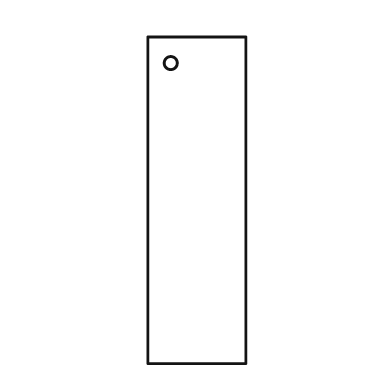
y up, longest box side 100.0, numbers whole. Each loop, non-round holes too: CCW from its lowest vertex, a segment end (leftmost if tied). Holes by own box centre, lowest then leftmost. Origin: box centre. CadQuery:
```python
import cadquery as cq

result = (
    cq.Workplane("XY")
    .moveTo(-15.0, -50.0)
    .lineTo(15.0, -50.0)
    .lineTo(15.0, 50.0)
    .lineTo(-15.0, 50.0)
    .close()
    .moveTo(-8.0, 42.0)
    .circle(2.0)
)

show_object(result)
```